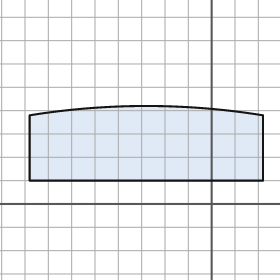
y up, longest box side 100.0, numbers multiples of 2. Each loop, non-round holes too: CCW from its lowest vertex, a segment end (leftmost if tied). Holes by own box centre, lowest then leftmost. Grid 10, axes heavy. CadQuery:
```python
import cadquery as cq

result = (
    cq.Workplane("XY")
    .moveTo(-78.0, 10.0)
    .lineTo(22.0, 10.0)
    .lineTo(22.0, 38.0)
    .threePointArc((-28.0, 42.0), (-78.0, 38.0))
    .close()
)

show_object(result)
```